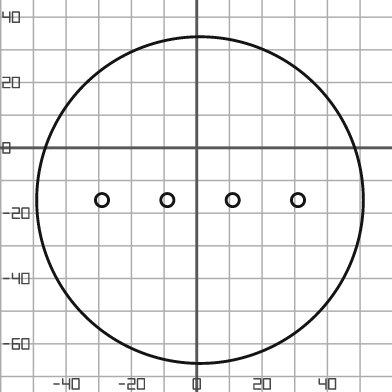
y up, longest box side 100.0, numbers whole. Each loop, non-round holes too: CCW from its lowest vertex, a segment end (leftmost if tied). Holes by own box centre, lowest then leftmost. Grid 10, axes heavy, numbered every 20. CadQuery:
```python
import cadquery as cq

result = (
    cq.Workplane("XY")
    .moveTo(1.0, -16.0)
    .circle(50.0)
    .moveTo(-29.0, -16.0)
    .circle(2.0)
    .moveTo(-9.0, -16.0)
    .circle(2.0)
    .moveTo(11.0, -16.0)
    .circle(2.0)
    .moveTo(31.0, -16.0)
    .circle(2.0)
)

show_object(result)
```